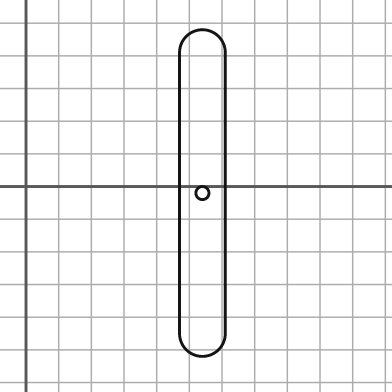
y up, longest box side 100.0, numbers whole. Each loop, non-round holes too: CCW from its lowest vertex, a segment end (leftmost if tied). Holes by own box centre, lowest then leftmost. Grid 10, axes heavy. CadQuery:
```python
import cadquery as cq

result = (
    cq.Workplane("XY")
    .moveTo(47.0, -45.0)
    .threePointArc((54.0, -52.0), (61.0, -45.0))
    .lineTo(61.0, 41.0)
    .threePointArc((54.0, 48.0), (47.0, 41.0))
    .close()
    .moveTo(54.0, -2.0)
    .circle(2.0)
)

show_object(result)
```